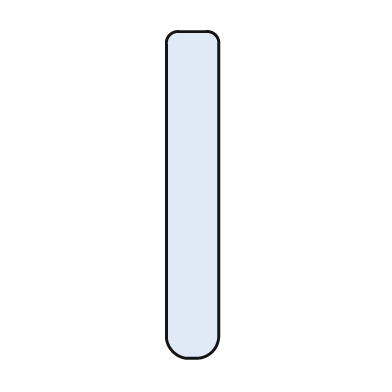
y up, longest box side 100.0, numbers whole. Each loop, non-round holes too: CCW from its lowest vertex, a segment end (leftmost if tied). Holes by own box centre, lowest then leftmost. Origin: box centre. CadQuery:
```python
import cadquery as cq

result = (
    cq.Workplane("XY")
    .moveTo(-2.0, -50.0)
    .lineTo(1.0, -50.0)
    .threePointArc((6.0, -48.0), (8.0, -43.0))
    .lineTo(8.0, 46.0)
    .threePointArc((7.0, 49.0), (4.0, 50.0))
    .lineTo(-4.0, 50.0)
    .threePointArc((-7.0, 49.0), (-8.0, 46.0))
    .lineTo(-8.0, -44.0)
    .threePointArc((-6.0, -48.0), (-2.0, -50.0))
    .close()
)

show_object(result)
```